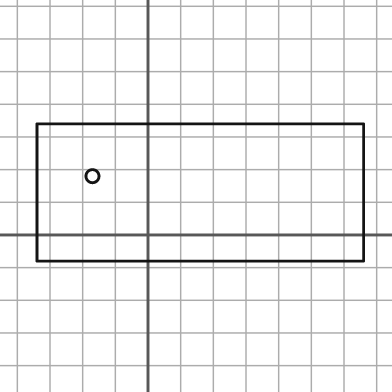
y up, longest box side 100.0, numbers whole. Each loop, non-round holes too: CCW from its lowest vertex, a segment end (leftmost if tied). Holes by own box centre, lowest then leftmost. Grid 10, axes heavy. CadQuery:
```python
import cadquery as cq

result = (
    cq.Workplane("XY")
    .moveTo(-34.0, -8.0)
    .lineTo(66.0, -8.0)
    .lineTo(66.0, 34.0)
    .lineTo(-34.0, 34.0)
    .close()
    .moveTo(-17.0, 18.0)
    .circle(2.0)
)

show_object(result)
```